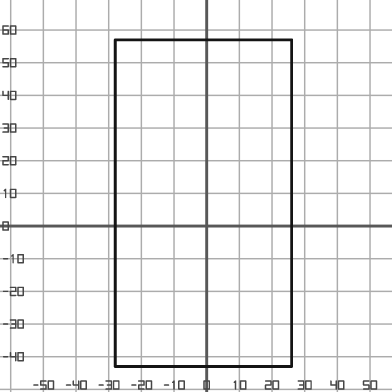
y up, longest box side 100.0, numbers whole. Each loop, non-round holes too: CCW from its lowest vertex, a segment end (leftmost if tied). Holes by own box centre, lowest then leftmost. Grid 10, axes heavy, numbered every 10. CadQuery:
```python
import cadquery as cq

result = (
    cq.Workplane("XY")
    .moveTo(-28.0, -43.0)
    .lineTo(26.0, -43.0)
    .lineTo(26.0, 57.0)
    .lineTo(-28.0, 57.0)
    .close()
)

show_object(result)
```